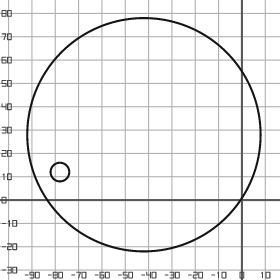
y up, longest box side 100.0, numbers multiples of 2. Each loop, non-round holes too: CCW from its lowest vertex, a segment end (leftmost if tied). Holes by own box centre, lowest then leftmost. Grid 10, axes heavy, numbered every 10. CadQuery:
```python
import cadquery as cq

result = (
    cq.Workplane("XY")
    .moveTo(-42.0, 28.0)
    .circle(50.0)
    .moveTo(-78.0, 12.0)
    .circle(4.0)
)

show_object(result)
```